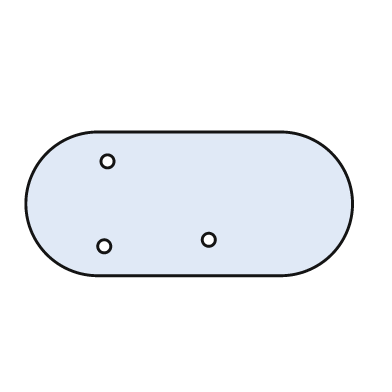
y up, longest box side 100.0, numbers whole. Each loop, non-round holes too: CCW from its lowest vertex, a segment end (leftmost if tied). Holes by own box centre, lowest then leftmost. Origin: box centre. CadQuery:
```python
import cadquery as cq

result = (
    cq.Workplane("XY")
    .moveTo(-28.0, -22.0)
    .lineTo(28.0, -22.0)
    .threePointArc((50.0, 0.0), (28.0, 22.0))
    .lineTo(-28.0, 22.0)
    .threePointArc((-50.0, 0.0), (-28.0, -22.0))
    .close()
    .moveTo(-26.0, -13.0)
    .circle(2.0)
    .moveTo(6.0, -11.0)
    .circle(2.0)
    .moveTo(-25.0, 13.0)
    .circle(2.0)
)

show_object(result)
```